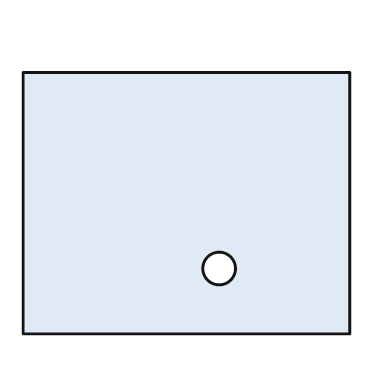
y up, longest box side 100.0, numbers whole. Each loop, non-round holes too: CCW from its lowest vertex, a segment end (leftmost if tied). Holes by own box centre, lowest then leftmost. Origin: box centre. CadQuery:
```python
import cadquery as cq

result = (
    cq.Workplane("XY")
    .moveTo(-50.0, -40.0)
    .lineTo(50.0, -40.0)
    .lineTo(50.0, 40.0)
    .lineTo(-50.0, 40.0)
    .close()
    .moveTo(10.0, -20.0)
    .circle(5.0)
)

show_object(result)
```